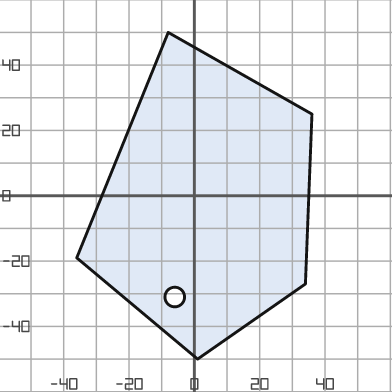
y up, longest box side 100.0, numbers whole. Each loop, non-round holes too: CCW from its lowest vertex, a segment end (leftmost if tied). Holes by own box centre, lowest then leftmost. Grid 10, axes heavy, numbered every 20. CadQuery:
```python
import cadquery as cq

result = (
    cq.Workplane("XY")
    .moveTo(1.0, -50.0)
    .lineTo(34.0, -27.0)
    .lineTo(36.0, 25.0)
    .lineTo(-8.0, 50.0)
    .lineTo(-36.0, -19.0)
    .close()
    .moveTo(-6.0, -31.0)
    .circle(3.0)
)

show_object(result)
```